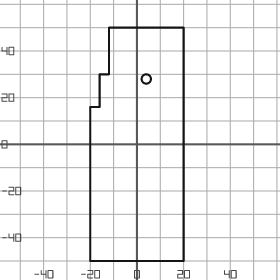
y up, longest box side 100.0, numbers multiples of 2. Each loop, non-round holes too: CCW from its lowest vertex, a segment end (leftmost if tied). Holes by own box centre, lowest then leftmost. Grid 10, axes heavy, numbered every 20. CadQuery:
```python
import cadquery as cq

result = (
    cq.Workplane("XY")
    .moveTo(-20.0, -50.0)
    .lineTo(20.0, -50.0)
    .lineTo(20.0, 50.0)
    .lineTo(-12.0, 50.0)
    .lineTo(-12.0, 30.0)
    .lineTo(-16.0, 30.0)
    .lineTo(-16.0, 16.0)
    .lineTo(-20.0, 16.0)
    .close()
    .moveTo(4.0, 28.0)
    .circle(2.0)
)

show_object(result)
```